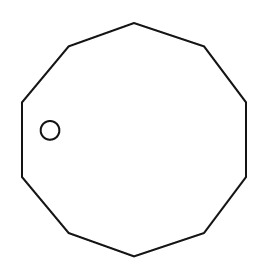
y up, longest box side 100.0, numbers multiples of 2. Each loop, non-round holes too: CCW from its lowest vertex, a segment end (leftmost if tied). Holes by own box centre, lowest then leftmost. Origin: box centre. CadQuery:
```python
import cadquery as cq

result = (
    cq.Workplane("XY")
    .moveTo(0.0, -50.0)
    .lineTo(30.0, -40.0)
    .lineTo(48.0, -16.0)
    .lineTo(48.0, 16.0)
    .lineTo(30.0, 40.0)
    .lineTo(0.0, 50.0)
    .lineTo(-28.0, 40.0)
    .lineTo(-48.0, 16.0)
    .lineTo(-48.0, -16.0)
    .lineTo(-28.0, -40.0)
    .close()
    .moveTo(-36.0, 4.0)
    .circle(4.0)
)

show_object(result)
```